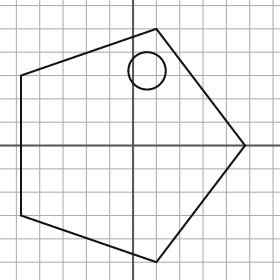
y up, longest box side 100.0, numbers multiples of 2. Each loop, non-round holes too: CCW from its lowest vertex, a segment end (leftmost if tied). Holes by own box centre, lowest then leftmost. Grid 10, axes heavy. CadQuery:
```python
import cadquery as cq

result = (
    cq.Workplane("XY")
    .moveTo(10.0, -50.0)
    .lineTo(48.0, 0.0)
    .lineTo(10.0, 50.0)
    .lineTo(-48.0, 30.0)
    .lineTo(-48.0, -30.0)
    .close()
    .moveTo(6.0, 32.0)
    .circle(8.0)
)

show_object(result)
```